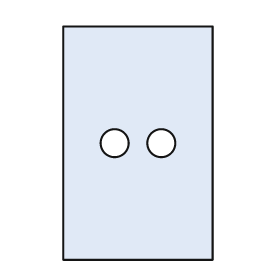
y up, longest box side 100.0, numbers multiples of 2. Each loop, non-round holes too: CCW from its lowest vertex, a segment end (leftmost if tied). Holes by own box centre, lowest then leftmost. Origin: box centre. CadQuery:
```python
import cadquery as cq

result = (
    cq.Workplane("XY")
    .moveTo(-32.0, -50.0)
    .lineTo(32.0, -50.0)
    .lineTo(32.0, 50.0)
    .lineTo(-32.0, 50.0)
    .close()
    .moveTo(-10.0, 0.0)
    .circle(6.0)
    .moveTo(10.0, 0.0)
    .circle(6.0)
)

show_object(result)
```